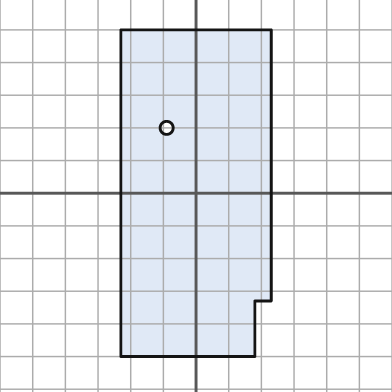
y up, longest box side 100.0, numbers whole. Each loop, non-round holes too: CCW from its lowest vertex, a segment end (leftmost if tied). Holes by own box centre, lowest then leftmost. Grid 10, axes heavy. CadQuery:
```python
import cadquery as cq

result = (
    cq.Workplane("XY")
    .moveTo(-23.0, -50.0)
    .lineTo(18.0, -50.0)
    .lineTo(18.0, -33.0)
    .lineTo(23.0, -33.0)
    .lineTo(23.0, 50.0)
    .lineTo(-23.0, 50.0)
    .close()
    .moveTo(-9.0, 20.0)
    .circle(2.0)
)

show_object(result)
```